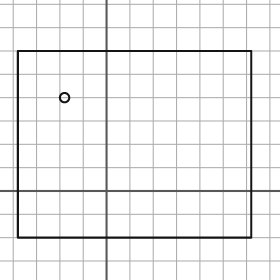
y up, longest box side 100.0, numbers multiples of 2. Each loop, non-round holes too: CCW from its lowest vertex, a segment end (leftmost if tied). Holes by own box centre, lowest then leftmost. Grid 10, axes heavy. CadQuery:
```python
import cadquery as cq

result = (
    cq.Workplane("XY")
    .moveTo(-38.0, -20.0)
    .lineTo(62.0, -20.0)
    .lineTo(62.0, 60.0)
    .lineTo(-38.0, 60.0)
    .close()
    .moveTo(-18.0, 40.0)
    .circle(2.0)
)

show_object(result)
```